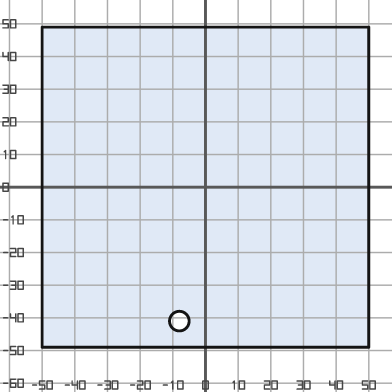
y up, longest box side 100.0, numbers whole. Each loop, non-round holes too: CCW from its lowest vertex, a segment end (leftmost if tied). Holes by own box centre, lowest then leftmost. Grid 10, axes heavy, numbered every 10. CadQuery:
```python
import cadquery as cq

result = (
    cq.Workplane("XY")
    .moveTo(-50.0, -49.0)
    .lineTo(50.0, -49.0)
    .lineTo(50.0, 49.0)
    .lineTo(-50.0, 49.0)
    .close()
    .moveTo(-8.0, -41.0)
    .circle(3.0)
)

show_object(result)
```